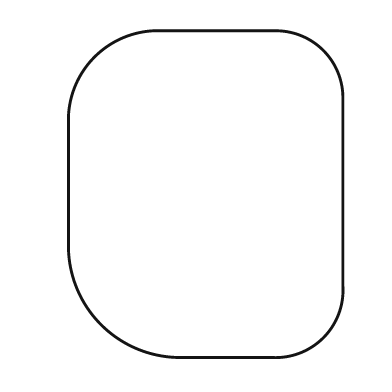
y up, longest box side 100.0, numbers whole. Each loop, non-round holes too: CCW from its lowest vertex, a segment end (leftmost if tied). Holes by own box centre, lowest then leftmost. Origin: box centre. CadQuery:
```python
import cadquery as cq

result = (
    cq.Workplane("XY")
    .moveTo(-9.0, -50.0)
    .lineTo(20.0, -50.0)
    .threePointArc((36.0, -44.0), (42.0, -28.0))
    .lineTo(42.0, 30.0)
    .threePointArc((36.0, 44.0), (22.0, 50.0))
    .lineTo(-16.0, 50.0)
    .threePointArc((-34.0, 42.0), (-42.0, 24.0))
    .lineTo(-42.0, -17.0)
    .threePointArc((-32.0, -40.0), (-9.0, -50.0))
    .close()
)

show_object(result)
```